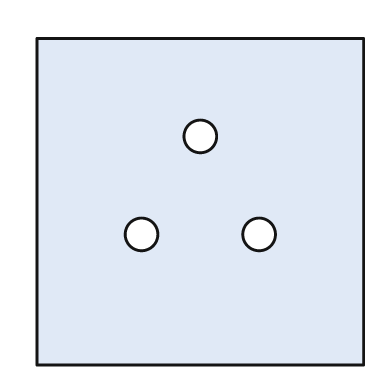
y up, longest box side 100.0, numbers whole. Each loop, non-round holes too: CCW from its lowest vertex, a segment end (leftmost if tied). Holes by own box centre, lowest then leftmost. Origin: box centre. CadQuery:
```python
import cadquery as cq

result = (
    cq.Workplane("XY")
    .moveTo(-50.0, -50.0)
    .lineTo(50.0, -50.0)
    .lineTo(50.0, 50.0)
    .lineTo(-50.0, 50.0)
    .close()
    .moveTo(-18.0, -10.0)
    .circle(5.0)
    .moveTo(18.0, -10.0)
    .circle(5.0)
    .moveTo(0.0, 20.0)
    .circle(5.0)
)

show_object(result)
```